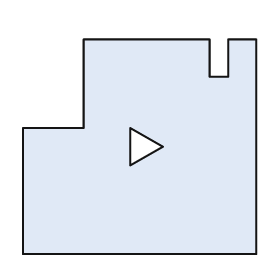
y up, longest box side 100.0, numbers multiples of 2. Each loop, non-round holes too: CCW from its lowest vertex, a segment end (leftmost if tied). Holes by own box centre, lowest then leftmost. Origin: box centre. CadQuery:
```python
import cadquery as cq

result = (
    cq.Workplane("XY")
    .moveTo(-50.0, -46.0)
    .lineTo(50.0, -46.0)
    .lineTo(50.0, 46.0)
    .lineTo(38.0, 46.0)
    .lineTo(38.0, 30.0)
    .lineTo(30.0, 30.0)
    .lineTo(30.0, 46.0)
    .lineTo(-24.0, 46.0)
    .lineTo(-24.0, 8.0)
    .lineTo(-50.0, 8.0)
    .close()
    .moveTo(-4.0, -8.0)
    .lineTo(10.0, 0.0)
    .lineTo(-4.0, 8.0)
    .close()
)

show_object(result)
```